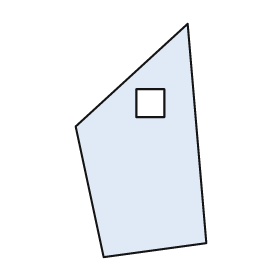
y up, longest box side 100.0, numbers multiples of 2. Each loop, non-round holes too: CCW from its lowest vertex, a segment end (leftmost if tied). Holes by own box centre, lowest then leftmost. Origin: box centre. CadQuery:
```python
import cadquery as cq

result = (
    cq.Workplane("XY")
    .moveTo(-16.0, -50.0)
    .lineTo(28.0, -44.0)
    .lineTo(20.0, 50.0)
    .lineTo(-28.0, 6.0)
    .close()
    .moveTo(-2.0, 10.0)
    .lineTo(10.0, 10.0)
    .lineTo(10.0, 22.0)
    .lineTo(-2.0, 22.0)
    .close()
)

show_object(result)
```